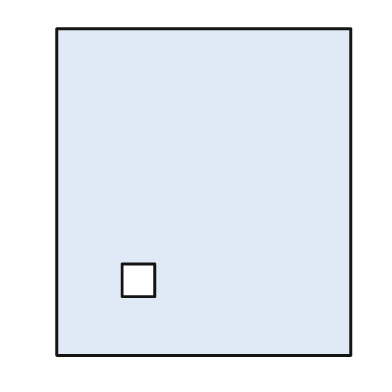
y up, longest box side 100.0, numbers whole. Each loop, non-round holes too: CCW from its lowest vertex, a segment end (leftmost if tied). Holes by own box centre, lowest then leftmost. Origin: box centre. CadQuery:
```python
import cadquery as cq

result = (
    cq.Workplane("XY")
    .moveTo(-45.0, -50.0)
    .lineTo(45.0, -50.0)
    .lineTo(45.0, 50.0)
    .lineTo(-45.0, 50.0)
    .close()
    .moveTo(-25.0, -32.0)
    .lineTo(-15.0, -32.0)
    .lineTo(-15.0, -22.0)
    .lineTo(-25.0, -22.0)
    .close()
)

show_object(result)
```